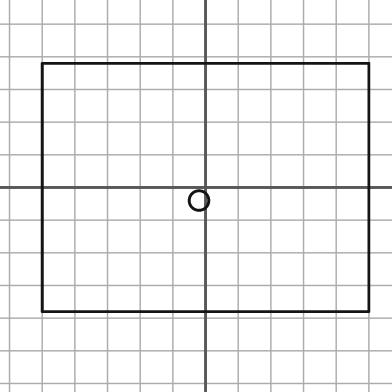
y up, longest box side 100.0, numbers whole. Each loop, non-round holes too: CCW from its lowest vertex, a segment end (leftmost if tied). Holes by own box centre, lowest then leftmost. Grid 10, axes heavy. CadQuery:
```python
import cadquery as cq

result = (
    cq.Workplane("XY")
    .moveTo(-50.0, -38.0)
    .lineTo(50.0, -38.0)
    .lineTo(50.0, 38.0)
    .lineTo(-50.0, 38.0)
    .close()
    .moveTo(-2.0, -4.0)
    .circle(3.0)
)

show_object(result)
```